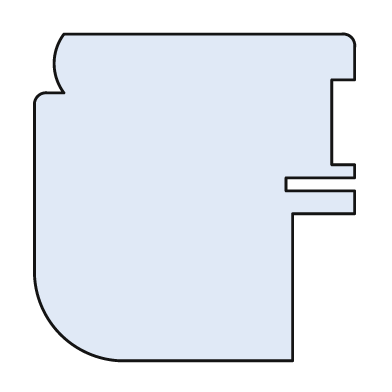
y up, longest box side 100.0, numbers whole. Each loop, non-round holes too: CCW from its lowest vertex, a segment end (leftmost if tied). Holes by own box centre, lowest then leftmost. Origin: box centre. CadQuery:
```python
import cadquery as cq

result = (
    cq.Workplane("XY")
    .moveTo(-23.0, -50.0)
    .lineTo(30.0, -50.0)
    .lineTo(30.0, -5.0)
    .lineTo(49.0, -5.0)
    .lineTo(49.0, 2.0)
    .lineTo(28.0, 2.0)
    .lineTo(28.0, 6.0)
    .lineTo(49.0, 6.0)
    .lineTo(49.0, 10.0)
    .lineTo(42.0, 10.0)
    .lineTo(42.0, 36.0)
    .lineTo(49.0, 36.0)
    .lineTo(49.0, 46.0)
    .threePointArc((48.0, 49.0), (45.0, 50.0))
    .lineTo(-40.0, 50.0)
    .threePointArc((-43.0, 41.0), (-40.0, 32.0))
    .lineTo(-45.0, 32.0)
    .threePointArc((-48.0, 31.0), (-49.0, 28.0))
    .lineTo(-49.0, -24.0)
    .threePointArc((-41.0, -42.0), (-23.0, -50.0))
    .close()
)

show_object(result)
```